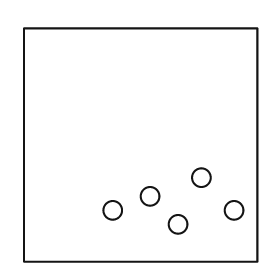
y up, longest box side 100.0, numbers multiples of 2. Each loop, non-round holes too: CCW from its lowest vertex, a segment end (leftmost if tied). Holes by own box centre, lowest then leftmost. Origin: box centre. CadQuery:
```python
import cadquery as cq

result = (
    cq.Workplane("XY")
    .moveTo(-50.0, -50.0)
    .lineTo(50.0, -50.0)
    .lineTo(50.0, 50.0)
    .lineTo(-50.0, 50.0)
    .close()
    .moveTo(16.0, -34.0)
    .circle(4.0)
    .moveTo(-12.0, -28.0)
    .circle(4.0)
    .moveTo(40.0, -28.0)
    .circle(4.0)
    .moveTo(4.0, -22.0)
    .circle(4.0)
    .moveTo(26.0, -14.0)
    .circle(4.0)
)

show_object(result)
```